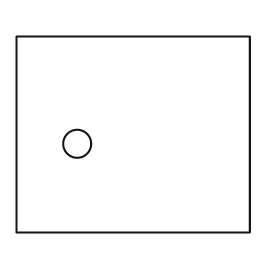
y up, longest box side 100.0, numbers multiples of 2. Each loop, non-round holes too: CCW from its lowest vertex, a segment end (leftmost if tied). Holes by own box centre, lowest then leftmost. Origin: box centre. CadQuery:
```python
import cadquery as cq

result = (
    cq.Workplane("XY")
    .moveTo(-50.0, -42.0)
    .lineTo(50.0, -42.0)
    .lineTo(50.0, 42.0)
    .lineTo(-50.0, 42.0)
    .close()
    .moveTo(-24.0, -4.0)
    .circle(6.0)
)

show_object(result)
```